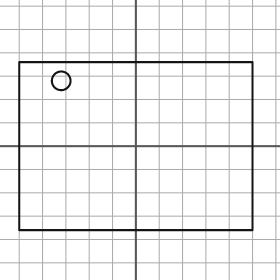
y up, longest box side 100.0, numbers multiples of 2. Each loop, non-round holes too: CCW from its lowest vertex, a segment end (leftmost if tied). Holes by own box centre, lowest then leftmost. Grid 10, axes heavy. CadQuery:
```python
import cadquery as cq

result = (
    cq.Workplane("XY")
    .moveTo(-50.0, -36.0)
    .lineTo(50.0, -36.0)
    .lineTo(50.0, 36.0)
    .lineTo(-50.0, 36.0)
    .close()
    .moveTo(-32.0, 28.0)
    .circle(4.0)
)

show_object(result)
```